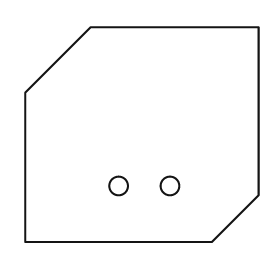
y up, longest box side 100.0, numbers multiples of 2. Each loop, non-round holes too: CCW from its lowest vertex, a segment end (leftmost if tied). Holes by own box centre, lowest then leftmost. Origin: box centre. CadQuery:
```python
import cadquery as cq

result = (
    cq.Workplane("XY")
    .moveTo(-50.0, -46.0)
    .lineTo(30.0, -46.0)
    .lineTo(50.0, -26.0)
    .lineTo(50.0, 46.0)
    .lineTo(-22.0, 46.0)
    .lineTo(-50.0, 18.0)
    .close()
    .moveTo(-10.0, -22.0)
    .circle(4.0)
    .moveTo(12.0, -22.0)
    .circle(4.0)
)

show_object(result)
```